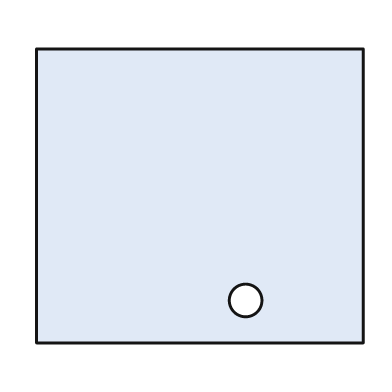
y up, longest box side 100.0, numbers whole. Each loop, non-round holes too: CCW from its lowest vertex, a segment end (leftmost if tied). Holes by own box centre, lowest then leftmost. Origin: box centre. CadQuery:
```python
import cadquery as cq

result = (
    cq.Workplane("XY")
    .moveTo(-50.0, -45.0)
    .lineTo(50.0, -45.0)
    .lineTo(50.0, 45.0)
    .lineTo(-50.0, 45.0)
    .close()
    .moveTo(14.0, -32.0)
    .circle(5.0)
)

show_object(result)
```